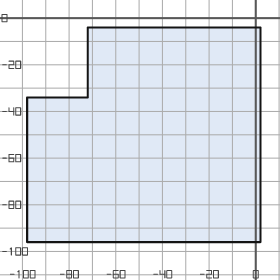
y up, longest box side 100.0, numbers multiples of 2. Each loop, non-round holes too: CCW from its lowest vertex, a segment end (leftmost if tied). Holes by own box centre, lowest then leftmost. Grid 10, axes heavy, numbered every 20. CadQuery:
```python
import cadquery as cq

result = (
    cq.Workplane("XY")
    .moveTo(-98.0, -96.0)
    .lineTo(2.0, -96.0)
    .lineTo(2.0, -4.0)
    .lineTo(-72.0, -4.0)
    .lineTo(-72.0, -34.0)
    .lineTo(-98.0, -34.0)
    .close()
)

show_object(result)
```